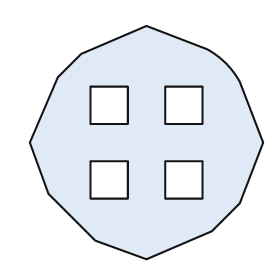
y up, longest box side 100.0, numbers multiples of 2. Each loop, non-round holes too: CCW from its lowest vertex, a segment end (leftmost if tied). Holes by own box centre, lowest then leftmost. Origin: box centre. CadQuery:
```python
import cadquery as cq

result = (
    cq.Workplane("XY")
    .moveTo(0.0, -50.0)
    .lineTo(28.0, -38.0)
    .lineTo(40.0, -26.0)
    .lineTo(50.0, 0.0)
    .lineTo(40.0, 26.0)
    .threePointArc((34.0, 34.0), (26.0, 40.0))
    .lineTo(0.0, 50.0)
    .lineTo(-28.0, 38.0)
    .lineTo(-38.0, 28.0)
    .lineTo(-50.0, 0.0)
    .lineTo(-42.0, -22.0)
    .lineTo(-22.0, -42.0)
    .close()
    .moveTo(-24.0, -24.0)
    .lineTo(-8.0, -24.0)
    .lineTo(-8.0, -8.0)
    .lineTo(-24.0, -8.0)
    .close()
    .moveTo(8.0, -24.0)
    .lineTo(24.0, -24.0)
    .lineTo(24.0, -8.0)
    .lineTo(8.0, -8.0)
    .close()
    .moveTo(-24.0, 8.0)
    .lineTo(-8.0, 8.0)
    .lineTo(-8.0, 24.0)
    .lineTo(-24.0, 24.0)
    .close()
    .moveTo(8.0, 8.0)
    .lineTo(24.0, 8.0)
    .lineTo(24.0, 24.0)
    .lineTo(8.0, 24.0)
    .close()
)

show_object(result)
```